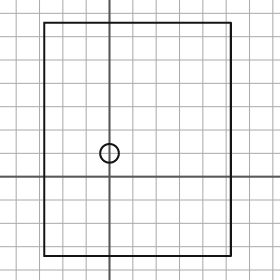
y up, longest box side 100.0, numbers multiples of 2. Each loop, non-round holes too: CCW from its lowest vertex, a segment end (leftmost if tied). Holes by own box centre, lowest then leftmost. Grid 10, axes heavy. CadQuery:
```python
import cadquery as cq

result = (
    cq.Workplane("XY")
    .moveTo(-28.0, -34.0)
    .lineTo(52.0, -34.0)
    .lineTo(52.0, 66.0)
    .lineTo(-28.0, 66.0)
    .close()
    .moveTo(0.0, 10.0)
    .circle(4.0)
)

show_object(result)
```